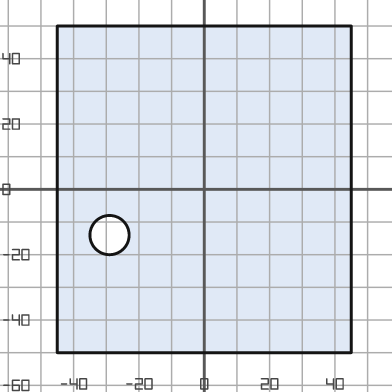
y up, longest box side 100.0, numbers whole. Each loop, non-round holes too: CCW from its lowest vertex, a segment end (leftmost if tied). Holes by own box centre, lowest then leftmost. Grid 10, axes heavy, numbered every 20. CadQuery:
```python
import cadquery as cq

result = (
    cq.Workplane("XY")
    .moveTo(-45.0, -50.0)
    .lineTo(45.0, -50.0)
    .lineTo(45.0, 50.0)
    .lineTo(-45.0, 50.0)
    .close()
    .moveTo(-29.0, -14.0)
    .circle(6.0)
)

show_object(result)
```